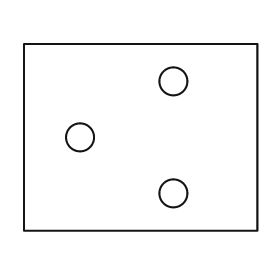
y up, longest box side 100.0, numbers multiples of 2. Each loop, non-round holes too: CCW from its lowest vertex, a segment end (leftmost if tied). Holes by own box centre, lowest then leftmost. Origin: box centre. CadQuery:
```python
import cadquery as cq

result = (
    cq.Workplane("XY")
    .moveTo(-50.0, -40.0)
    .lineTo(50.0, -40.0)
    .lineTo(50.0, 40.0)
    .lineTo(-50.0, 40.0)
    .close()
    .moveTo(14.0, -24.0)
    .circle(6.0)
    .moveTo(-26.0, 0.0)
    .circle(6.0)
    .moveTo(14.0, 24.0)
    .circle(6.0)
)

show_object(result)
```